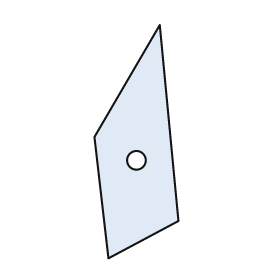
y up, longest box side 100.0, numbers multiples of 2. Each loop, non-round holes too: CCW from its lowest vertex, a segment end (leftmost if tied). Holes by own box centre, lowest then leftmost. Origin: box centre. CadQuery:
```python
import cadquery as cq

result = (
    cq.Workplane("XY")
    .moveTo(-12.0, -50.0)
    .lineTo(18.0, -34.0)
    .lineTo(10.0, 50.0)
    .lineTo(-18.0, 2.0)
    .close()
    .moveTo(0.0, -8.0)
    .circle(4.0)
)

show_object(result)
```